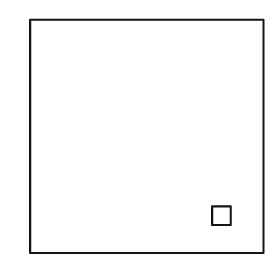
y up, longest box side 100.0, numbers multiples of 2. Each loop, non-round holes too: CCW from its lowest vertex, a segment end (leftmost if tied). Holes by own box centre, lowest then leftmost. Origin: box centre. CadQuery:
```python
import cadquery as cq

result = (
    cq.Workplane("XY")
    .moveTo(-50.0, -50.0)
    .lineTo(50.0, -50.0)
    .lineTo(50.0, 50.0)
    .lineTo(-50.0, 50.0)
    .close()
    .moveTo(28.0, -38.0)
    .lineTo(36.0, -38.0)
    .lineTo(36.0, -30.0)
    .lineTo(28.0, -30.0)
    .close()
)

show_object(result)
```